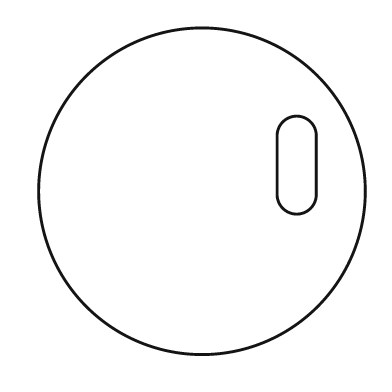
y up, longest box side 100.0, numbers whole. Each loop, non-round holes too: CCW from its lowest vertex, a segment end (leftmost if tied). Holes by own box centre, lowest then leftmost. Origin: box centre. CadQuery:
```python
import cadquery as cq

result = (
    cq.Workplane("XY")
    .moveTo(0.0, 0.0)
    .circle(50.0)
    .moveTo(23.0, -1.0)
    .threePointArc((29.0, -7.0), (35.0, -1.0))
    .lineTo(35.0, 17.0)
    .threePointArc((29.0, 23.0), (23.0, 17.0))
    .close()
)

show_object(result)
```